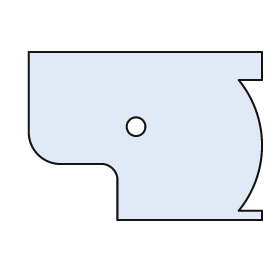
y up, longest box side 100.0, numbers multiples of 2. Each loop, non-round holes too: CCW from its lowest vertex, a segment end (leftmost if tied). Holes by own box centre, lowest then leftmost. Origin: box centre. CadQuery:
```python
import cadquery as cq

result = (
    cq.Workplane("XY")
    .moveTo(-12.0, -36.0)
    .lineTo(50.0, -36.0)
    .lineTo(50.0, -32.0)
    .lineTo(40.0, -32.0)
    .threePointArc((50.0, -4.0), (40.0, 24.0))
    .lineTo(50.0, 24.0)
    .lineTo(50.0, 36.0)
    .lineTo(-50.0, 36.0)
    .lineTo(-50.0, 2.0)
    .threePointArc((-46.0, -8.0), (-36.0, -12.0))
    .lineTo(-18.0, -12.0)
    .threePointArc((-14.0, -14.0), (-12.0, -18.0))
    .close()
    .moveTo(-4.0, 4.0)
    .circle(4.0)
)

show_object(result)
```